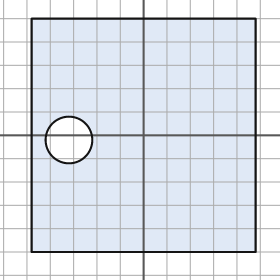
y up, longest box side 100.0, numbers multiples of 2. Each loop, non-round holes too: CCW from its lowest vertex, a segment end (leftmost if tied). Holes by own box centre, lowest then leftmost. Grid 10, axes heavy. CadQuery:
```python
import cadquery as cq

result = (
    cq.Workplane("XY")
    .moveTo(-48.0, -50.0)
    .lineTo(48.0, -50.0)
    .lineTo(48.0, 50.0)
    .lineTo(-48.0, 50.0)
    .close()
    .moveTo(-32.0, -2.0)
    .circle(10.0)
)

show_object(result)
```